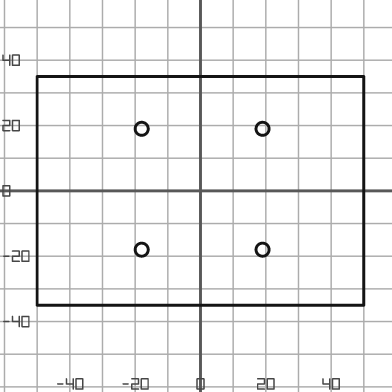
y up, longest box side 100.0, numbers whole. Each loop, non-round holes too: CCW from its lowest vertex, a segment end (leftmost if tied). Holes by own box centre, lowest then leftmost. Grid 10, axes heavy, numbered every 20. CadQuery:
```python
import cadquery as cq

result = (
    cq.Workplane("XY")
    .moveTo(-50.0, -35.0)
    .lineTo(50.0, -35.0)
    .lineTo(50.0, 35.0)
    .lineTo(-50.0, 35.0)
    .close()
    .moveTo(-18.0, -18.0)
    .circle(2.0)
    .moveTo(19.0, -18.0)
    .circle(2.0)
    .moveTo(-18.0, 19.0)
    .circle(2.0)
    .moveTo(19.0, 19.0)
    .circle(2.0)
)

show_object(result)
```